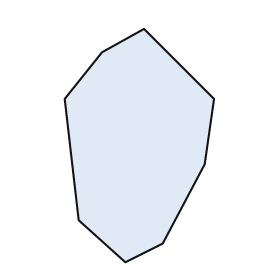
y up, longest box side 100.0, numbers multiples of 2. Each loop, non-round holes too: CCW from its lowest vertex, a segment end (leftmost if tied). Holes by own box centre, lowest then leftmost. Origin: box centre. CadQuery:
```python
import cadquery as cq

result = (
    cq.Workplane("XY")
    .moveTo(-6.0, -50.0)
    .lineTo(10.0, -42.0)
    .lineTo(28.0, -8.0)
    .lineTo(32.0, 20.0)
    .lineTo(2.0, 50.0)
    .lineTo(-16.0, 40.0)
    .lineTo(-32.0, 20.0)
    .lineTo(-26.0, -32.0)
    .close()
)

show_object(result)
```